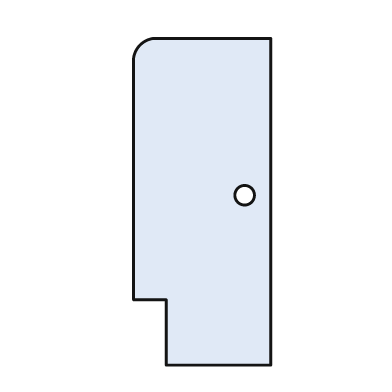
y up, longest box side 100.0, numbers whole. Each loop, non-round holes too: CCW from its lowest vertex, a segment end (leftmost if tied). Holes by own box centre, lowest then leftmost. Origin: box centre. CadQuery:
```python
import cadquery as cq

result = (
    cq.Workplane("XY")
    .moveTo(-11.0, -50.0)
    .lineTo(21.0, -50.0)
    .lineTo(21.0, 50.0)
    .lineTo(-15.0, 50.0)
    .threePointArc((-19.0, 48.0), (-21.0, 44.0))
    .lineTo(-21.0, -30.0)
    .lineTo(-11.0, -30.0)
    .close()
    .moveTo(13.0, 2.0)
    .circle(3.0)
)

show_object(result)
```